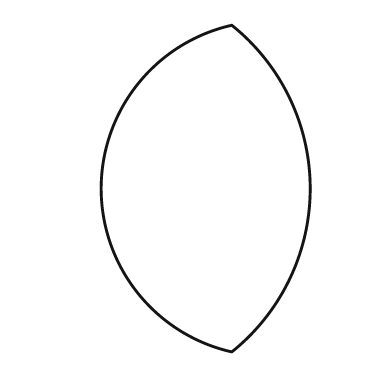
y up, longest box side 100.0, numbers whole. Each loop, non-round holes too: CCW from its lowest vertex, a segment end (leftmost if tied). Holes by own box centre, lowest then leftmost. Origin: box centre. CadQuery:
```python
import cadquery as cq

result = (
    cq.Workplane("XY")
    .moveTo(8.0, -50.0)
    .threePointArc((32.0, 0.0), (8.0, 50.0))
    .threePointArc((-32.0, 0.0), (8.0, -50.0))
    .close()
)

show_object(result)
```